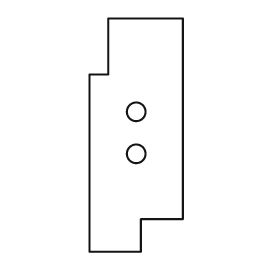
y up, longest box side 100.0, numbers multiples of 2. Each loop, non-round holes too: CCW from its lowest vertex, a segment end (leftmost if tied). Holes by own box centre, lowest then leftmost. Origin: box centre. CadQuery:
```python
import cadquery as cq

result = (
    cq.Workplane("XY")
    .moveTo(-20.0, -50.0)
    .lineTo(2.0, -50.0)
    .lineTo(2.0, -36.0)
    .lineTo(20.0, -36.0)
    .lineTo(20.0, 50.0)
    .lineTo(-12.0, 50.0)
    .lineTo(-12.0, 26.0)
    .lineTo(-20.0, 26.0)
    .close()
    .moveTo(0.0, -8.0)
    .circle(4.0)
    .moveTo(0.0, 10.0)
    .circle(4.0)
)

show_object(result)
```